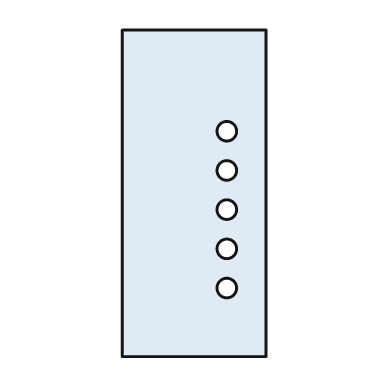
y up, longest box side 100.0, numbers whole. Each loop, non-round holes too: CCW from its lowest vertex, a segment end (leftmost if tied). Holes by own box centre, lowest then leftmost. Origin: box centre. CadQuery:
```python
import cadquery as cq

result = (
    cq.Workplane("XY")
    .moveTo(-22.0, -50.0)
    .lineTo(22.0, -50.0)
    .lineTo(22.0, 50.0)
    .lineTo(-22.0, 50.0)
    .close()
    .moveTo(10.0, -29.0)
    .circle(3.0)
    .moveTo(10.0, -17.0)
    .circle(3.0)
    .moveTo(10.0, -5.0)
    .circle(3.0)
    .moveTo(10.0, 7.0)
    .circle(3.0)
    .moveTo(10.0, 19.0)
    .circle(3.0)
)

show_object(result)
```